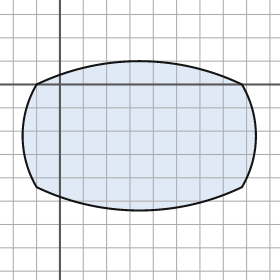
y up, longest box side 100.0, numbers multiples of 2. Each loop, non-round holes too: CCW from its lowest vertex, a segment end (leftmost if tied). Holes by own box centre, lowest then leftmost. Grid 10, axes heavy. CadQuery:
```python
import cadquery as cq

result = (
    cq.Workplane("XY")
    .moveTo(-10.0, -44.0)
    .threePointArc((34.0, -54.0), (78.0, -44.0))
    .threePointArc((84.0, -22.0), (78.0, 0.0))
    .threePointArc((34.0, 10.0), (-10.0, 0.0))
    .threePointArc((-16.0, -22.0), (-10.0, -44.0))
    .close()
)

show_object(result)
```